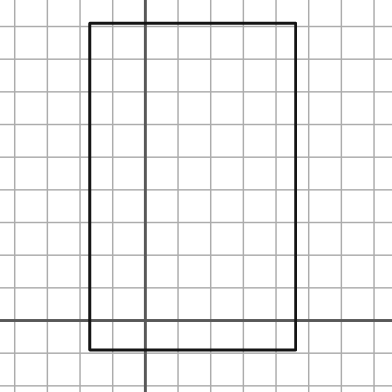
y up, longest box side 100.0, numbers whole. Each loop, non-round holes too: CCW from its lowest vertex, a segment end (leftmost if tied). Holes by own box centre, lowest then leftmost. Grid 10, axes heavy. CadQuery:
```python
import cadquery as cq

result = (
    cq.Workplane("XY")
    .moveTo(-17.0, -9.0)
    .lineTo(46.0, -9.0)
    .lineTo(46.0, 91.0)
    .lineTo(-17.0, 91.0)
    .close()
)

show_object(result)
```